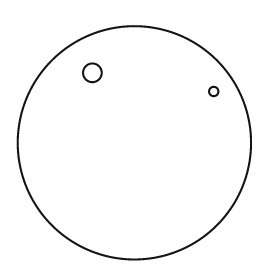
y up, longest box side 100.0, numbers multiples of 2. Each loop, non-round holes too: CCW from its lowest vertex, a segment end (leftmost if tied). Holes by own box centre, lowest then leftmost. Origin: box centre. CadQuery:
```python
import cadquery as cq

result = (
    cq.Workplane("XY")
    .moveTo(0.0, 0.0)
    .circle(50.0)
    .moveTo(34.0, 22.0)
    .circle(2.0)
    .moveTo(-18.0, 30.0)
    .circle(4.0)
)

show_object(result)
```